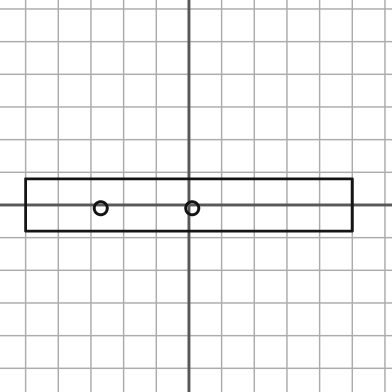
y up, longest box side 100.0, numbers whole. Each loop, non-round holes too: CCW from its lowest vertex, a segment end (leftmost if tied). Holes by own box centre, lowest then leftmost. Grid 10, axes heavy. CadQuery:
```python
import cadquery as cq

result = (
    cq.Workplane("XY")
    .moveTo(-50.0, -8.0)
    .lineTo(50.0, -8.0)
    .lineTo(50.0, 8.0)
    .lineTo(-50.0, 8.0)
    .close()
    .moveTo(-27.0, -1.0)
    .circle(2.0)
    .moveTo(1.0, -1.0)
    .circle(2.0)
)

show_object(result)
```